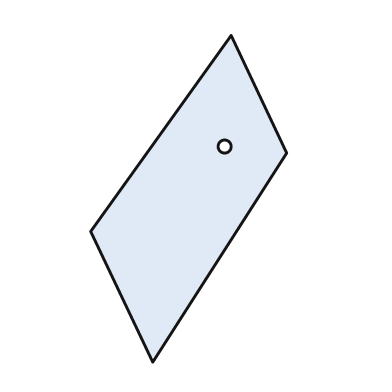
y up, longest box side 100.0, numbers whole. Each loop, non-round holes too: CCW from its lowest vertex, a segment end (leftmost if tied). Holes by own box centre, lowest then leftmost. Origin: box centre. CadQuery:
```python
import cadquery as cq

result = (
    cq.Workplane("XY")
    .moveTo(-11.0, -50.0)
    .lineTo(30.0, 14.0)
    .lineTo(13.0, 50.0)
    .lineTo(-30.0, -10.0)
    .close()
    .moveTo(11.0, 16.0)
    .circle(2.0)
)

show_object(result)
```